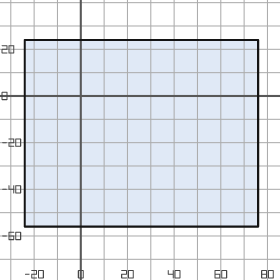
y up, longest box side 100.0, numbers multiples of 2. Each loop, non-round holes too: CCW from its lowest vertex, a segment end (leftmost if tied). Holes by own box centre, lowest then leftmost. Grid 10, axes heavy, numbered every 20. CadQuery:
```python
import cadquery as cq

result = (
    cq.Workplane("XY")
    .moveTo(-24.0, -56.0)
    .lineTo(76.0, -56.0)
    .lineTo(76.0, 24.0)
    .lineTo(-24.0, 24.0)
    .close()
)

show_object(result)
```